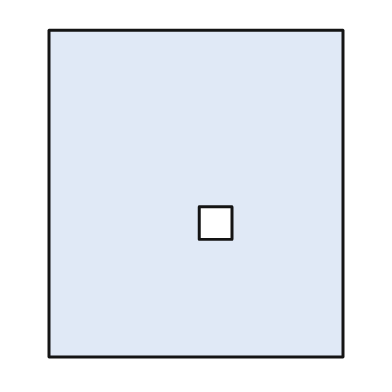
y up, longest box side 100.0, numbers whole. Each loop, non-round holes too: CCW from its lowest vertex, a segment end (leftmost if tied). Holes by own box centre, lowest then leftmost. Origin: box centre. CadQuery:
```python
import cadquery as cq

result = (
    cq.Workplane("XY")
    .moveTo(-45.0, -50.0)
    .lineTo(45.0, -50.0)
    .lineTo(45.0, 50.0)
    .lineTo(-45.0, 50.0)
    .close()
    .moveTo(1.0, -14.0)
    .lineTo(11.0, -14.0)
    .lineTo(11.0, -4.0)
    .lineTo(1.0, -4.0)
    .close()
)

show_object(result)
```